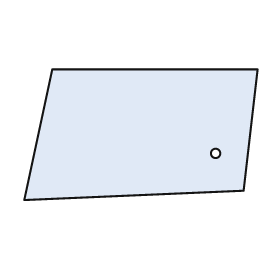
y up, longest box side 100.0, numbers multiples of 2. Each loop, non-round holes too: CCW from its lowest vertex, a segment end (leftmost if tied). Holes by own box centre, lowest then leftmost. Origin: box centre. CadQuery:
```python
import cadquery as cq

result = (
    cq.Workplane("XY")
    .moveTo(-50.0, -28.0)
    .lineTo(44.0, -24.0)
    .lineTo(50.0, 28.0)
    .lineTo(-38.0, 28.0)
    .close()
    .moveTo(32.0, -8.0)
    .circle(2.0)
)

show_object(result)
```